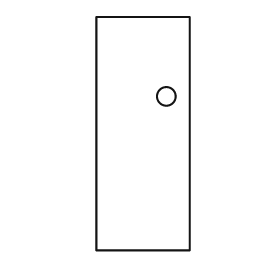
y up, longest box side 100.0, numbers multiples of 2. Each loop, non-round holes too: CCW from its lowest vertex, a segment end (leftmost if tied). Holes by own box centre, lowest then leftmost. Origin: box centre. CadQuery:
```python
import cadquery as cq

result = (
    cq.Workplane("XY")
    .moveTo(-20.0, -50.0)
    .lineTo(20.0, -50.0)
    .lineTo(20.0, 50.0)
    .lineTo(-20.0, 50.0)
    .close()
    .moveTo(10.0, 16.0)
    .circle(4.0)
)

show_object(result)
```